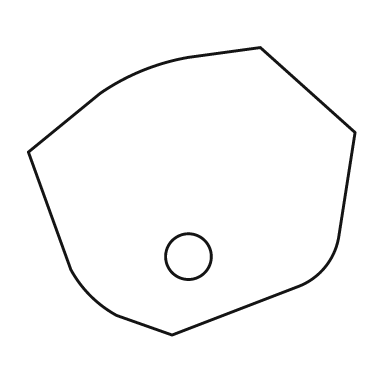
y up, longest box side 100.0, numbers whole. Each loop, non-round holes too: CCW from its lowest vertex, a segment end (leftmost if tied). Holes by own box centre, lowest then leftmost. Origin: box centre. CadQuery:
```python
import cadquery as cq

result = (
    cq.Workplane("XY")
    .moveTo(-6.0, -44.0)
    .lineTo(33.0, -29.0)
    .threePointArc((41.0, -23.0), (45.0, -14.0))
    .lineTo(50.0, 18.0)
    .lineTo(21.0, 44.0)
    .lineTo(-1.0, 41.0)
    .threePointArc((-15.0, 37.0), (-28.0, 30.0))
    .lineTo(-50.0, 12.0)
    .lineTo(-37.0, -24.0)
    .threePointArc((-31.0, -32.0), (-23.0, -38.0))
    .close()
    .moveTo(-1.0, -20.0)
    .circle(7.0)
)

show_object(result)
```